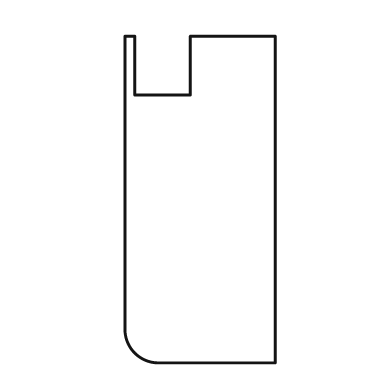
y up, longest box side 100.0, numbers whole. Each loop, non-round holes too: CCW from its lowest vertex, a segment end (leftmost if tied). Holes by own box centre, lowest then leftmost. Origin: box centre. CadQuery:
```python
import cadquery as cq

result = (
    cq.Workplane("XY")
    .moveTo(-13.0, -50.0)
    .lineTo(23.0, -50.0)
    .lineTo(23.0, 50.0)
    .lineTo(-3.0, 50.0)
    .lineTo(-3.0, 32.0)
    .lineTo(-20.0, 32.0)
    .lineTo(-20.0, 50.0)
    .lineTo(-23.0, 50.0)
    .lineTo(-23.0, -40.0)
    .threePointArc((-20.0, -47.0), (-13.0, -50.0))
    .close()
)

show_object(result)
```